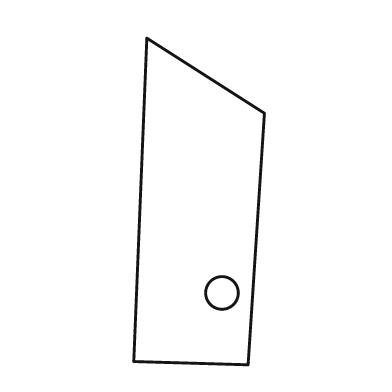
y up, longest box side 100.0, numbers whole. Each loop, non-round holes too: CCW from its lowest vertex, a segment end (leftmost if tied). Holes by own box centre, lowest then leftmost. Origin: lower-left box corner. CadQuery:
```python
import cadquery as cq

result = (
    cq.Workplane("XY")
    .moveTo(35.0, 0.0)
    .lineTo(40.0, 77.0)
    .lineTo(4.0, 100.0)
    .lineTo(0.0, 1.0)
    .close()
    .moveTo(27.0, 22.0)
    .circle(5.0)
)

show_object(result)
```